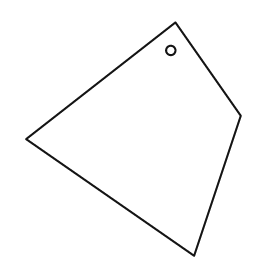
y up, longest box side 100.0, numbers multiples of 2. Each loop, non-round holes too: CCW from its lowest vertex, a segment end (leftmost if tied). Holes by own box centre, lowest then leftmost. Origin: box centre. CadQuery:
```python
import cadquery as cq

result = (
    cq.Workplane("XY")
    .moveTo(26.0, -50.0)
    .lineTo(46.0, 10.0)
    .lineTo(18.0, 50.0)
    .lineTo(-46.0, 0.0)
    .close()
    .moveTo(16.0, 38.0)
    .circle(2.0)
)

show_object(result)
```